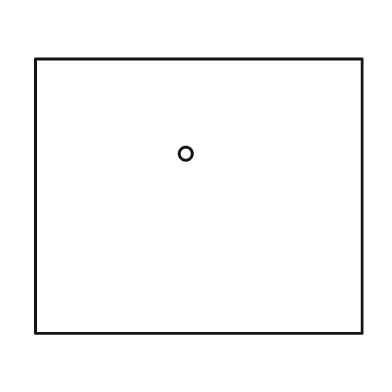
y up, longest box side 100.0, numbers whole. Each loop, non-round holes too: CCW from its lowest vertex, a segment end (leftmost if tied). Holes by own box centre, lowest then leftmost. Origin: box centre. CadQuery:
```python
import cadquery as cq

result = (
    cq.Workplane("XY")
    .moveTo(-50.0, -42.0)
    .lineTo(50.0, -42.0)
    .lineTo(50.0, 42.0)
    .lineTo(-50.0, 42.0)
    .close()
    .moveTo(-4.0, 13.0)
    .circle(2.0)
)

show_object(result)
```